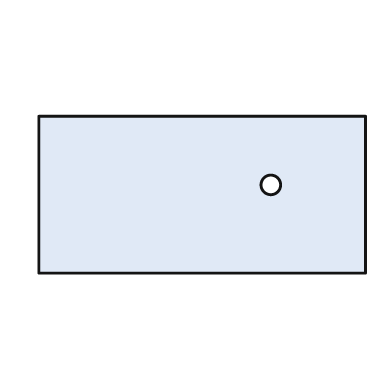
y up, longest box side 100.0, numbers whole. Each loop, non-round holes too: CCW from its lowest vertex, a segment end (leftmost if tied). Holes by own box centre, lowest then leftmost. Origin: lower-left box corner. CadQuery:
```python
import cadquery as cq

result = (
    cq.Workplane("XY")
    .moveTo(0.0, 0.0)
    .lineTo(100.0, 0.0)
    .lineTo(100.0, 48.0)
    .lineTo(0.0, 48.0)
    .close()
    .moveTo(71.0, 27.0)
    .circle(3.0)
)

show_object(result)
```